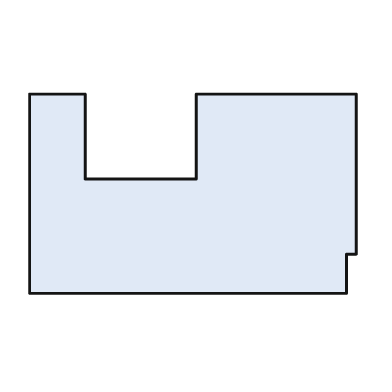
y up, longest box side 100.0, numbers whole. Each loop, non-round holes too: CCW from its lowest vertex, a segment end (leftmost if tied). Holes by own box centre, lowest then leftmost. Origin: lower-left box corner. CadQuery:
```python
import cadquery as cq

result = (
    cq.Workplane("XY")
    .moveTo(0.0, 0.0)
    .lineTo(97.0, 0.0)
    .lineTo(97.0, 12.0)
    .lineTo(100.0, 12.0)
    .lineTo(100.0, 61.0)
    .lineTo(51.0, 61.0)
    .lineTo(51.0, 35.0)
    .lineTo(17.0, 35.0)
    .lineTo(17.0, 61.0)
    .lineTo(0.0, 61.0)
    .close()
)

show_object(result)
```